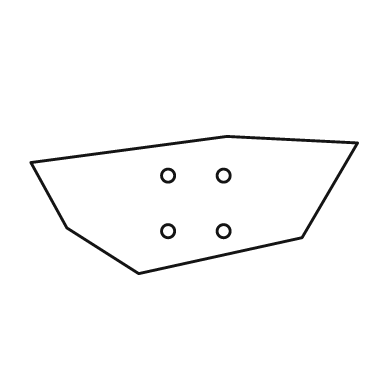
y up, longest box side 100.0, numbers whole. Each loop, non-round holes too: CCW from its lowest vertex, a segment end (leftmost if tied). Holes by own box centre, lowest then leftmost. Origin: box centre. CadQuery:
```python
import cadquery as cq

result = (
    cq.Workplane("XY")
    .moveTo(-17.0, -21.0)
    .lineTo(33.0, -10.0)
    .lineTo(50.0, 19.0)
    .lineTo(10.0, 21.0)
    .lineTo(-50.0, 13.0)
    .lineTo(-39.0, -7.0)
    .close()
    .moveTo(-8.0, -8.0)
    .circle(2.0)
    .moveTo(9.0, -8.0)
    .circle(2.0)
    .moveTo(-8.0, 9.0)
    .circle(2.0)
    .moveTo(9.0, 9.0)
    .circle(2.0)
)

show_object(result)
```